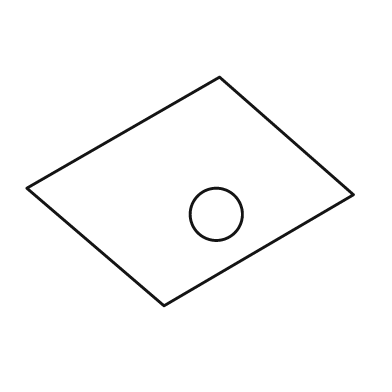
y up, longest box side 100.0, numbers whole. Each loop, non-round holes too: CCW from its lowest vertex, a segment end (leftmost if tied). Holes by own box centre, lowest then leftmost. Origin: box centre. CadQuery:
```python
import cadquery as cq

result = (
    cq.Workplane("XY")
    .moveTo(-8.0, -35.0)
    .lineTo(50.0, -1.0)
    .lineTo(9.0, 35.0)
    .lineTo(-50.0, 1.0)
    .close()
    .moveTo(8.0, -7.0)
    .circle(8.0)
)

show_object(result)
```